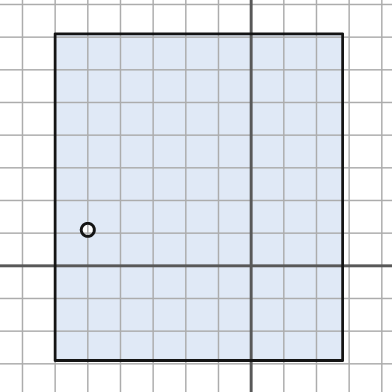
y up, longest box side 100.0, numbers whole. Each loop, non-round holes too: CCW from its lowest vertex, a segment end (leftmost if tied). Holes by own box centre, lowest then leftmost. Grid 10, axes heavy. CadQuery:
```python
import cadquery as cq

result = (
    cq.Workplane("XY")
    .moveTo(-60.0, -29.0)
    .lineTo(28.0, -29.0)
    .lineTo(28.0, 71.0)
    .lineTo(-60.0, 71.0)
    .close()
    .moveTo(-50.0, 11.0)
    .circle(2.0)
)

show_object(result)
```